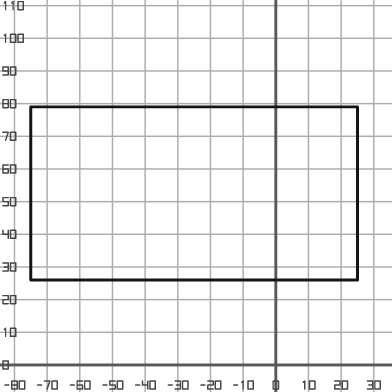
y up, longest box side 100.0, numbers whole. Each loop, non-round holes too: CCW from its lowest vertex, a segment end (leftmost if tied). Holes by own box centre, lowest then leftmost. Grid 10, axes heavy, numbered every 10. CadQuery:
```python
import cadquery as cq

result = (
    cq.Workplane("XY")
    .moveTo(-75.0, 26.0)
    .lineTo(25.0, 26.0)
    .lineTo(25.0, 79.0)
    .lineTo(-75.0, 79.0)
    .close()
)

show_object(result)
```